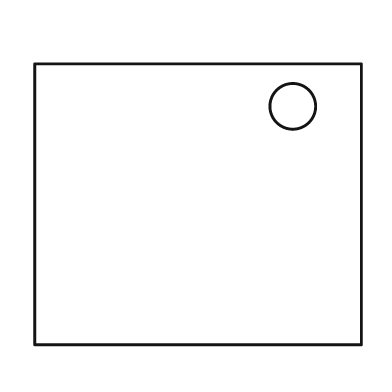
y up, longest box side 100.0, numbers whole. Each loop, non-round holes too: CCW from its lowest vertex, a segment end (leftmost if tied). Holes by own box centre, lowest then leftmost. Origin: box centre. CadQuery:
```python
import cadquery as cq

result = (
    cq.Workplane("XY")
    .moveTo(-50.0, -43.0)
    .lineTo(50.0, -43.0)
    .lineTo(50.0, 43.0)
    .lineTo(-50.0, 43.0)
    .close()
    .moveTo(29.0, 30.0)
    .circle(7.0)
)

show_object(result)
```